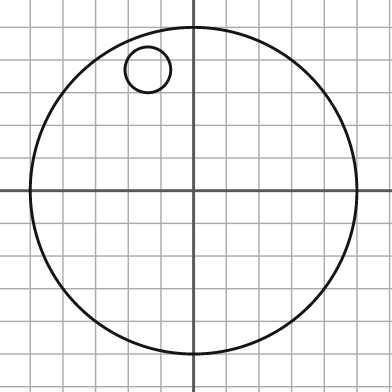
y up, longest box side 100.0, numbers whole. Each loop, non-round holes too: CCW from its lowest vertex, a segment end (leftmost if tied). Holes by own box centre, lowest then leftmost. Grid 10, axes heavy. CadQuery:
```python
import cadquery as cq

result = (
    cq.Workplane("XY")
    .moveTo(0.0, 0.0)
    .circle(50.0)
    .moveTo(-14.0, 37.0)
    .circle(7.0)
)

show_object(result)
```